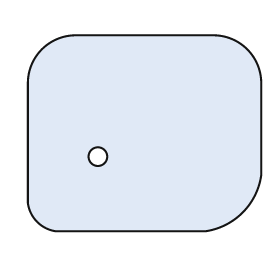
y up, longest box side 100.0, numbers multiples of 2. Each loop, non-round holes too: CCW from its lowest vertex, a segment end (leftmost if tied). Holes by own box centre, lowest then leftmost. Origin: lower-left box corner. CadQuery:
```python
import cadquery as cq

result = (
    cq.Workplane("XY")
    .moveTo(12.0, 0.0)
    .lineTo(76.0, 0.0)
    .threePointArc((92.0, 8.0), (100.0, 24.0))
    .lineTo(100.0, 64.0)
    .threePointArc((94.0, 78.0), (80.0, 84.0))
    .lineTo(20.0, 84.0)
    .threePointArc((6.0, 78.0), (0.0, 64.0))
    .lineTo(0.0, 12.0)
    .threePointArc((4.0, 4.0), (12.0, 0.0))
    .close()
    .moveTo(30.0, 32.0)
    .circle(4.0)
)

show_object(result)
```